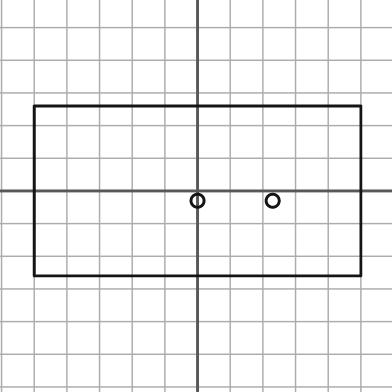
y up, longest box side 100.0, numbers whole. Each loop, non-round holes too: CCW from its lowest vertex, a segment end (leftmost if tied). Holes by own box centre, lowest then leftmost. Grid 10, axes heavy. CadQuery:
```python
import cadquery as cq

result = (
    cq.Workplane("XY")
    .moveTo(-50.0, -26.0)
    .lineTo(50.0, -26.0)
    .lineTo(50.0, 26.0)
    .lineTo(-50.0, 26.0)
    .close()
    .moveTo(0.0, -3.0)
    .circle(2.0)
    .moveTo(23.0, -3.0)
    .circle(2.0)
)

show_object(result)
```